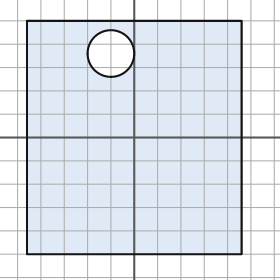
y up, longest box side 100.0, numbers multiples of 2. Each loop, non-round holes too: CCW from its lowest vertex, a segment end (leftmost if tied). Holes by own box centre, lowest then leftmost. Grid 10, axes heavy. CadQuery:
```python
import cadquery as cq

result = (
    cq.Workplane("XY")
    .moveTo(-46.0, -50.0)
    .lineTo(46.0, -50.0)
    .lineTo(46.0, 50.0)
    .lineTo(-46.0, 50.0)
    .close()
    .moveTo(-10.0, 36.0)
    .circle(10.0)
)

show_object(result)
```